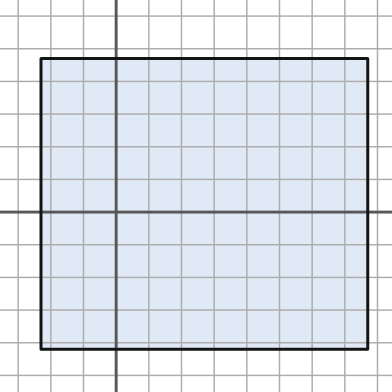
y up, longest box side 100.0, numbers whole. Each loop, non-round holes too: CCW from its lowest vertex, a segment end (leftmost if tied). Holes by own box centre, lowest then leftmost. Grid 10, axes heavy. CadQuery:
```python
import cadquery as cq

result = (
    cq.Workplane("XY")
    .moveTo(-23.0, -42.0)
    .lineTo(77.0, -42.0)
    .lineTo(77.0, 47.0)
    .lineTo(-23.0, 47.0)
    .close()
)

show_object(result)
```